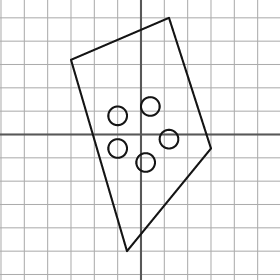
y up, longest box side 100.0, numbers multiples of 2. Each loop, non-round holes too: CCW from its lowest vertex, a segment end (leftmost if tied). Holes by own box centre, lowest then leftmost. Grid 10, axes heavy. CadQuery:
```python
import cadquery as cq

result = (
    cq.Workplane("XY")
    .moveTo(-6.0, -50.0)
    .lineTo(30.0, -6.0)
    .lineTo(12.0, 50.0)
    .lineTo(-30.0, 32.0)
    .close()
    .moveTo(2.0, -12.0)
    .circle(4.0)
    .moveTo(-10.0, -6.0)
    .circle(4.0)
    .moveTo(12.0, -2.0)
    .circle(4.0)
    .moveTo(-10.0, 8.0)
    .circle(4.0)
    .moveTo(4.0, 12.0)
    .circle(4.0)
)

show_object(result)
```